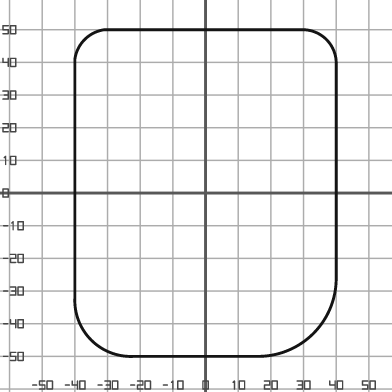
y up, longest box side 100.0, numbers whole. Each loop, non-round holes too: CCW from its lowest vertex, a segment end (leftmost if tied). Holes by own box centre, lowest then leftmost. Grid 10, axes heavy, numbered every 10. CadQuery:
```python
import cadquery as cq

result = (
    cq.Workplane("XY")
    .moveTo(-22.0, -50.0)
    .lineTo(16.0, -50.0)
    .threePointArc((33.0, -43.0), (40.0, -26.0))
    .lineTo(40.0, 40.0)
    .threePointArc((37.0, 47.0), (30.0, 50.0))
    .lineTo(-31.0, 50.0)
    .threePointArc((-37.0, 47.0), (-40.0, 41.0))
    .lineTo(-40.0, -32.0)
    .threePointArc((-35.0, -45.0), (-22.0, -50.0))
    .close()
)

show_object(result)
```